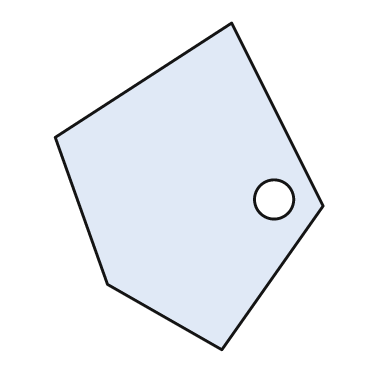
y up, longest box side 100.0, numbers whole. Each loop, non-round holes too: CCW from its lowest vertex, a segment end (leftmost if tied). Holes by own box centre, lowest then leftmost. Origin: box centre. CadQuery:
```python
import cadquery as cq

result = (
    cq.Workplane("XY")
    .moveTo(10.0, -50.0)
    .lineTo(41.0, -6.0)
    .lineTo(13.0, 50.0)
    .lineTo(-41.0, 15.0)
    .lineTo(-25.0, -30.0)
    .close()
    .moveTo(26.0, -4.0)
    .circle(6.0)
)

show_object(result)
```